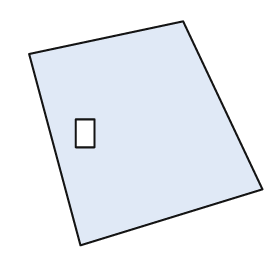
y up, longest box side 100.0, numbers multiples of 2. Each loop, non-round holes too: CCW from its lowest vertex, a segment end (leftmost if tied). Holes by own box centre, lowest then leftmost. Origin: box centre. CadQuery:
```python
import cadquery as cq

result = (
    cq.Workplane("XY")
    .moveTo(-28.0, -48.0)
    .lineTo(50.0, -24.0)
    .lineTo(16.0, 48.0)
    .lineTo(-50.0, 34.0)
    .close()
    .moveTo(-30.0, -6.0)
    .lineTo(-22.0, -6.0)
    .lineTo(-22.0, 6.0)
    .lineTo(-30.0, 6.0)
    .close()
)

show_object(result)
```